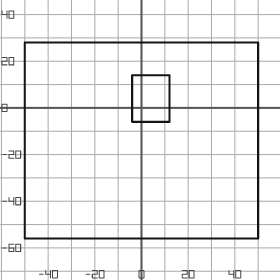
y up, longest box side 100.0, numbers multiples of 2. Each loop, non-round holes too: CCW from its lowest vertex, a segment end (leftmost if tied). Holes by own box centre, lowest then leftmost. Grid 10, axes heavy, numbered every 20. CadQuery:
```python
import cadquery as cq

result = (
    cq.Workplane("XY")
    .moveTo(-50.0, -56.0)
    .lineTo(50.0, -56.0)
    .lineTo(50.0, 28.0)
    .lineTo(-50.0, 28.0)
    .close()
    .moveTo(-4.0, -6.0)
    .lineTo(12.0, -6.0)
    .lineTo(12.0, 14.0)
    .lineTo(-4.0, 14.0)
    .close()
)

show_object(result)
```